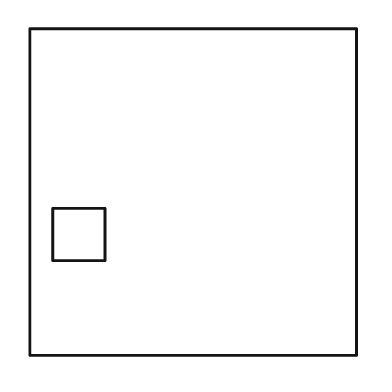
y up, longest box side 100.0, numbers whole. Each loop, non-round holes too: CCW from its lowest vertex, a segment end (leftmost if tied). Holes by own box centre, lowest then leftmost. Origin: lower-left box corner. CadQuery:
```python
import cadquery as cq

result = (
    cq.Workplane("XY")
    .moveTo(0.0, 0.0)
    .lineTo(100.0, 0.0)
    .lineTo(100.0, 100.0)
    .lineTo(0.0, 100.0)
    .close()
    .moveTo(7.0, 29.0)
    .lineTo(23.0, 29.0)
    .lineTo(23.0, 45.0)
    .lineTo(7.0, 45.0)
    .close()
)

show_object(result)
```